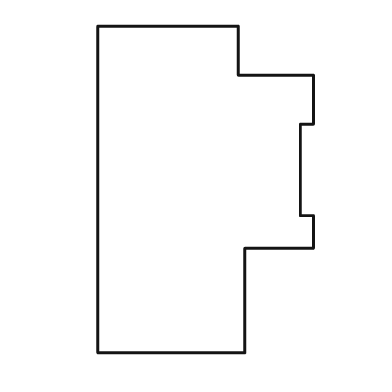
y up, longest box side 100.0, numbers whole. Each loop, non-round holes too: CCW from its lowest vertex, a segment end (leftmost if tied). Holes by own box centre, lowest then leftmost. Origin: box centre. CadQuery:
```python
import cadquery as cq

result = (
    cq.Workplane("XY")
    .moveTo(-33.0, -50.0)
    .lineTo(12.0, -50.0)
    .lineTo(12.0, -18.0)
    .lineTo(33.0, -18.0)
    .lineTo(33.0, -8.0)
    .lineTo(29.0, -8.0)
    .lineTo(29.0, 20.0)
    .lineTo(33.0, 20.0)
    .lineTo(33.0, 35.0)
    .lineTo(10.0, 35.0)
    .lineTo(10.0, 50.0)
    .lineTo(-33.0, 50.0)
    .close()
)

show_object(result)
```